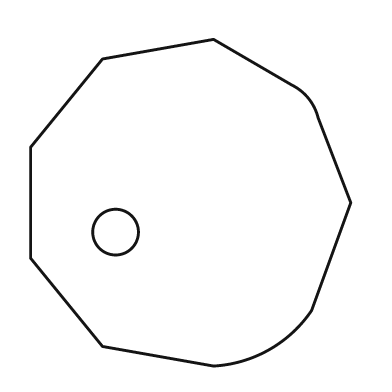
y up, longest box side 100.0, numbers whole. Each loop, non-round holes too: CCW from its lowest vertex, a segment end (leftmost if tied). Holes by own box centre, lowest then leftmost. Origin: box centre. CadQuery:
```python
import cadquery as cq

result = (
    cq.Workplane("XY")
    .moveTo(7.0, -50.0)
    .threePointArc((24.0, -45.0), (37.0, -33.0))
    .lineTo(49.0, 0.0)
    .lineTo(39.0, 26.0)
    .threePointArc((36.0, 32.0), (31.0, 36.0))
    .lineTo(7.0, 50.0)
    .lineTo(-27.0, 44.0)
    .lineTo(-49.0, 17.0)
    .lineTo(-49.0, -17.0)
    .lineTo(-27.0, -44.0)
    .close()
    .moveTo(-23.0, -9.0)
    .circle(7.0)
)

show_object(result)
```